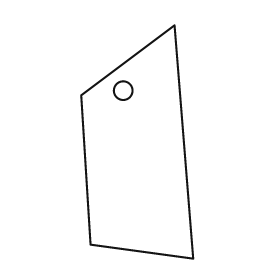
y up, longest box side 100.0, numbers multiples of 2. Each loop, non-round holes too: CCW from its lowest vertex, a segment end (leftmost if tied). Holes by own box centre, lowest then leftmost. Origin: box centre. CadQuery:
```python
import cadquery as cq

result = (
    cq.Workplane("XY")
    .moveTo(24.0, -50.0)
    .lineTo(16.0, 50.0)
    .lineTo(-24.0, 20.0)
    .lineTo(-20.0, -44.0)
    .close()
    .moveTo(-6.0, 22.0)
    .circle(4.0)
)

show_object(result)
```